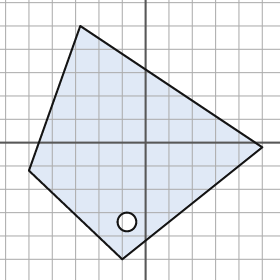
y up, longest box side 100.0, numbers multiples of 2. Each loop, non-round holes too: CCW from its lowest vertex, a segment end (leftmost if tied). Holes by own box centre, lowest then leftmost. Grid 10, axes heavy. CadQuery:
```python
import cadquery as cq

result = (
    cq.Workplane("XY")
    .moveTo(-10.0, -50.0)
    .lineTo(50.0, -2.0)
    .lineTo(-28.0, 50.0)
    .lineTo(-50.0, -12.0)
    .close()
    .moveTo(-8.0, -34.0)
    .circle(4.0)
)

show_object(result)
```